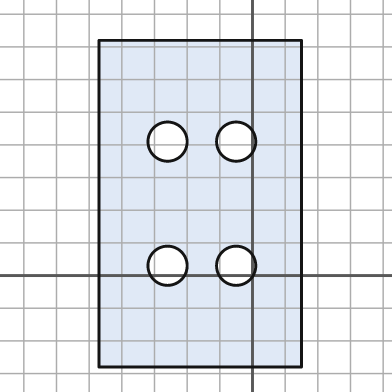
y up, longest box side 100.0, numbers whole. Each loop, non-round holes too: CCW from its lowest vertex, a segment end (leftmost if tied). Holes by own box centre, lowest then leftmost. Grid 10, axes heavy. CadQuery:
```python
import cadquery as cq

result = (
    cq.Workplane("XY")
    .moveTo(-47.0, -28.0)
    .lineTo(15.0, -28.0)
    .lineTo(15.0, 72.0)
    .lineTo(-47.0, 72.0)
    .close()
    .moveTo(-26.0, 3.0)
    .circle(6.0)
    .moveTo(-5.0, 3.0)
    .circle(6.0)
    .moveTo(-26.0, 41.0)
    .circle(6.0)
    .moveTo(-5.0, 41.0)
    .circle(6.0)
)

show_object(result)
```